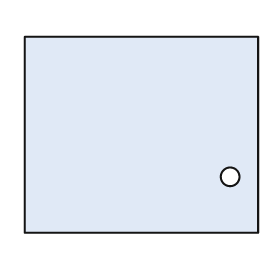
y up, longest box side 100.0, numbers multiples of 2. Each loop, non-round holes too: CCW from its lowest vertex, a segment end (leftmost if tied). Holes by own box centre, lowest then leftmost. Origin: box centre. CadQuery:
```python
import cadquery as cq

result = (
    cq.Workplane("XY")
    .moveTo(-50.0, -42.0)
    .lineTo(50.0, -42.0)
    .lineTo(50.0, 42.0)
    .lineTo(-50.0, 42.0)
    .close()
    .moveTo(38.0, -18.0)
    .circle(4.0)
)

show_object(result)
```